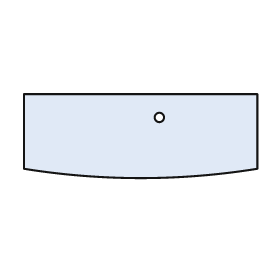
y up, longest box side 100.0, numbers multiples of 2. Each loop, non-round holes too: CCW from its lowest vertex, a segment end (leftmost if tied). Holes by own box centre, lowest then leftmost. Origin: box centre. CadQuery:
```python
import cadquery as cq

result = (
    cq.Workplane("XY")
    .moveTo(-50.0, -14.0)
    .threePointArc((0.0, -18.0), (50.0, -14.0))
    .lineTo(50.0, 18.0)
    .lineTo(-50.0, 18.0)
    .close()
    .moveTo(8.0, 8.0)
    .circle(2.0)
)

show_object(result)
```